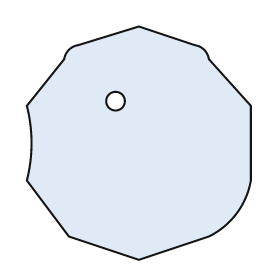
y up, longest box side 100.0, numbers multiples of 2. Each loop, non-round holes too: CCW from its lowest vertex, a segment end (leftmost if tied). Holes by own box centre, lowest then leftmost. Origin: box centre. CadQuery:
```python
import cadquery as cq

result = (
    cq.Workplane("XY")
    .moveTo(0.0, -50.0)
    .lineTo(30.0, -40.0)
    .threePointArc((42.0, -30.0), (48.0, -16.0))
    .lineTo(48.0, 16.0)
    .lineTo(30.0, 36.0)
    .threePointArc((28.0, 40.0), (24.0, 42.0))
    .lineTo(0.0, 50.0)
    .lineTo(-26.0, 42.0)
    .threePointArc((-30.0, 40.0), (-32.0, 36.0))
    .lineTo(-48.0, 16.0)
    .threePointArc((-46.0, 0.0), (-48.0, -16.0))
    .lineTo(-30.0, -40.0)
    .close()
    .moveTo(-10.0, 18.0)
    .circle(4.0)
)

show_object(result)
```